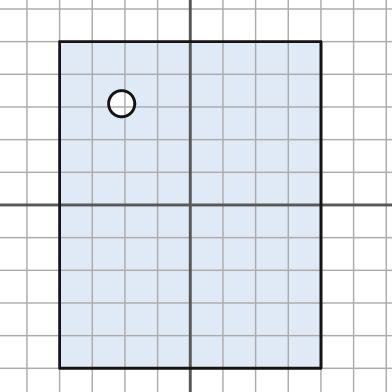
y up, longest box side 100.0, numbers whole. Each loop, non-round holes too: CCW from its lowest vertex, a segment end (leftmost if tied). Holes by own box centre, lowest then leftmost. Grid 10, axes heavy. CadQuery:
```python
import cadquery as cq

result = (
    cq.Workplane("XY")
    .moveTo(-40.0, -50.0)
    .lineTo(40.0, -50.0)
    .lineTo(40.0, 50.0)
    .lineTo(-40.0, 50.0)
    .close()
    .moveTo(-21.0, 31.0)
    .circle(4.0)
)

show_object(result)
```